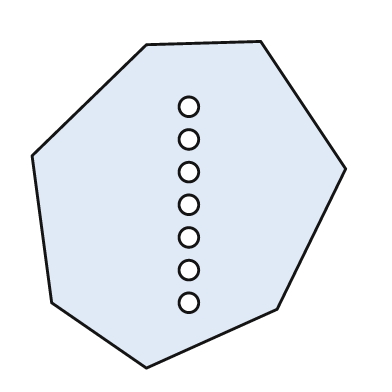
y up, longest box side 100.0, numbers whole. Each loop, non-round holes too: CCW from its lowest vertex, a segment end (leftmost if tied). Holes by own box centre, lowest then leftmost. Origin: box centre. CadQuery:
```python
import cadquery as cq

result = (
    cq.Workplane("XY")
    .moveTo(-13.0, -50.0)
    .lineTo(27.0, -32.0)
    .lineTo(48.0, 11.0)
    .lineTo(22.0, 50.0)
    .lineTo(-13.0, 49.0)
    .lineTo(-48.0, 15.0)
    .lineTo(-42.0, -30.0)
    .close()
    .moveTo(0.0, -30.0)
    .circle(3.0)
    .moveTo(0.0, -20.0)
    .circle(3.0)
    .moveTo(0.0, -10.0)
    .circle(3.0)
    .moveTo(0.0, 0.0)
    .circle(3.0)
    .moveTo(0.0, 10.0)
    .circle(3.0)
    .moveTo(0.0, 20.0)
    .circle(3.0)
    .moveTo(0.0, 30.0)
    .circle(3.0)
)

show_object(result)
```